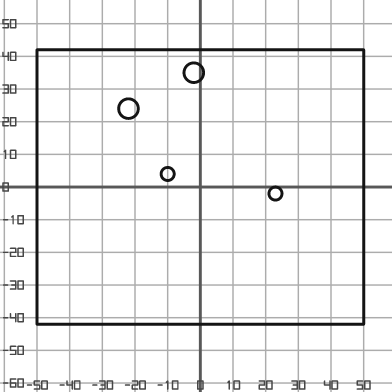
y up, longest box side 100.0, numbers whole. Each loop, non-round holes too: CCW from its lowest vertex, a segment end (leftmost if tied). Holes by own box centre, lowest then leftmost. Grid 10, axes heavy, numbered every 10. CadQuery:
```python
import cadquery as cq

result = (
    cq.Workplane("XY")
    .moveTo(-50.0, -42.0)
    .lineTo(50.0, -42.0)
    .lineTo(50.0, 42.0)
    .lineTo(-50.0, 42.0)
    .close()
    .moveTo(23.0, -2.0)
    .circle(2.0)
    .moveTo(-10.0, 4.0)
    .circle(2.0)
    .moveTo(-22.0, 24.0)
    .circle(3.0)
    .moveTo(-2.0, 35.0)
    .circle(3.0)
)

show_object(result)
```